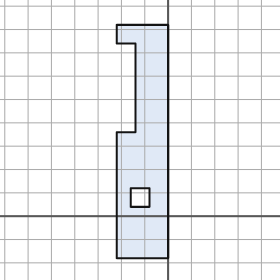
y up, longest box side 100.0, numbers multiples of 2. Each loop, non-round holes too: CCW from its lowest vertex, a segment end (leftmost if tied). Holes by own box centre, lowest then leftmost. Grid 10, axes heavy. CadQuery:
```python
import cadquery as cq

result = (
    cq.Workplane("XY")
    .moveTo(-22.0, -18.0)
    .lineTo(0.0, -18.0)
    .lineTo(0.0, 82.0)
    .lineTo(-22.0, 82.0)
    .lineTo(-22.0, 74.0)
    .lineTo(-14.0, 74.0)
    .lineTo(-14.0, 36.0)
    .lineTo(-22.0, 36.0)
    .close()
    .moveTo(-16.0, 4.0)
    .lineTo(-8.0, 4.0)
    .lineTo(-8.0, 12.0)
    .lineTo(-16.0, 12.0)
    .close()
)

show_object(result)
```